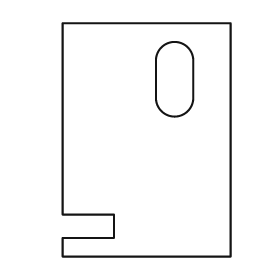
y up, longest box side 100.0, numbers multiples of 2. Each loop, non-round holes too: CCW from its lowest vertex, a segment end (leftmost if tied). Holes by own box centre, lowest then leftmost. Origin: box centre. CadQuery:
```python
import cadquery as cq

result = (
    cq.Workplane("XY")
    .moveTo(-36.0, -50.0)
    .lineTo(36.0, -50.0)
    .lineTo(36.0, 50.0)
    .lineTo(-36.0, 50.0)
    .lineTo(-36.0, -32.0)
    .lineTo(-14.0, -32.0)
    .lineTo(-14.0, -42.0)
    .lineTo(-36.0, -42.0)
    .close()
    .moveTo(4.0, 18.0)
    .threePointArc((12.0, 10.0), (20.0, 18.0))
    .lineTo(20.0, 34.0)
    .threePointArc((12.0, 42.0), (4.0, 34.0))
    .close()
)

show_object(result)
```